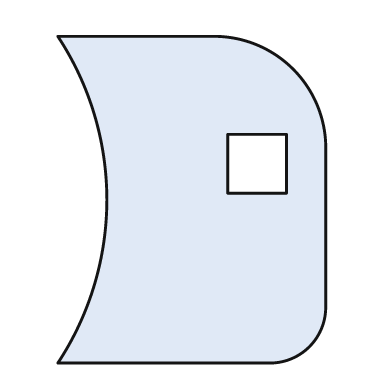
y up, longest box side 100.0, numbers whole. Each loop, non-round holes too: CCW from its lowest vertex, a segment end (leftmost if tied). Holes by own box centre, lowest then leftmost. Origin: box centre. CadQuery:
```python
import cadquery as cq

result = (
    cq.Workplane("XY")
    .moveTo(-41.0, -50.0)
    .lineTo(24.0, -50.0)
    .threePointArc((36.0, -45.0), (41.0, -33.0))
    .lineTo(41.0, 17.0)
    .threePointArc((31.0, 40.0), (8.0, 50.0))
    .lineTo(-41.0, 50.0)
    .threePointArc((-26.0, 0.0), (-41.0, -50.0))
    .close()
    .moveTo(11.0, 2.0)
    .lineTo(29.0, 2.0)
    .lineTo(29.0, 20.0)
    .lineTo(11.0, 20.0)
    .close()
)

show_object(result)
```